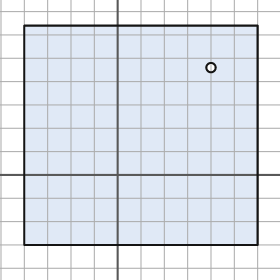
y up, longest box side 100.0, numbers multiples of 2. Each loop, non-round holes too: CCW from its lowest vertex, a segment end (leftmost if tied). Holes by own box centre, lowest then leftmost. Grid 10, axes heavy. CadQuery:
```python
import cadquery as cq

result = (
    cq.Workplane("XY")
    .moveTo(-40.0, -30.0)
    .lineTo(60.0, -30.0)
    .lineTo(60.0, 64.0)
    .lineTo(-40.0, 64.0)
    .close()
    .moveTo(40.0, 46.0)
    .circle(2.0)
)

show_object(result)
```